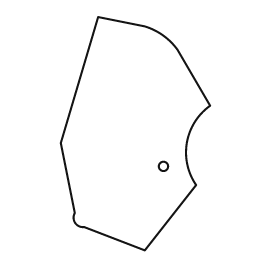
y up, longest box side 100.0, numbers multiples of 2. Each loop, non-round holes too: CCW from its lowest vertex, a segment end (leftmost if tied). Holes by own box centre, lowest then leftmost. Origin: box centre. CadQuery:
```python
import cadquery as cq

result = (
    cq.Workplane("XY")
    .moveTo(4.0, -50.0)
    .lineTo(26.0, -22.0)
    .threePointArc((22.0, -4.0), (32.0, 12.0))
    .lineTo(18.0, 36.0)
    .threePointArc((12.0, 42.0), (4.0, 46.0))
    .lineTo(-16.0, 50.0)
    .lineTo(-32.0, -4.0)
    .lineTo(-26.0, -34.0)
    .threePointArc((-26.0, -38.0), (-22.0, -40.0))
    .close()
    .moveTo(12.0, -14.0)
    .circle(2.0)
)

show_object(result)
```